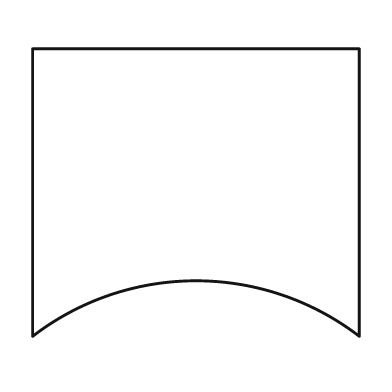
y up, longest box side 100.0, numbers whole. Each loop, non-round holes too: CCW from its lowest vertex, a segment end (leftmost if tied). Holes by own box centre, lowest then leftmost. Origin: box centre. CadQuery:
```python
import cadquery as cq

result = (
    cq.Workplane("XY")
    .moveTo(-50.0, -44.0)
    .threePointArc((0.0, -27.0), (50.0, -44.0))
    .lineTo(50.0, 44.0)
    .lineTo(-50.0, 44.0)
    .close()
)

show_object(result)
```